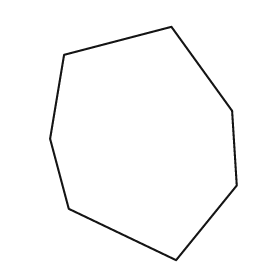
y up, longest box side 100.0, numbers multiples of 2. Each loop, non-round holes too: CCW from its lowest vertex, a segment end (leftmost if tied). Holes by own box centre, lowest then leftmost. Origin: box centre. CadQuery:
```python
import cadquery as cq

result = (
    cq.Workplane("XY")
    .moveTo(14.0, -50.0)
    .lineTo(40.0, -18.0)
    .lineTo(38.0, 14.0)
    .lineTo(12.0, 50.0)
    .lineTo(-34.0, 38.0)
    .lineTo(-40.0, 2.0)
    .lineTo(-32.0, -28.0)
    .close()
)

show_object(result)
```